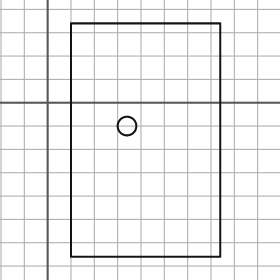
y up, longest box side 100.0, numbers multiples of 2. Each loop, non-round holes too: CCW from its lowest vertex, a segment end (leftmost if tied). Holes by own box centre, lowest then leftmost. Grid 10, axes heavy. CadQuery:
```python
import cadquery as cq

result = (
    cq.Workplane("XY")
    .moveTo(10.0, -66.0)
    .lineTo(74.0, -66.0)
    .lineTo(74.0, 34.0)
    .lineTo(10.0, 34.0)
    .close()
    .moveTo(34.0, -10.0)
    .circle(4.0)
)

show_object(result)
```